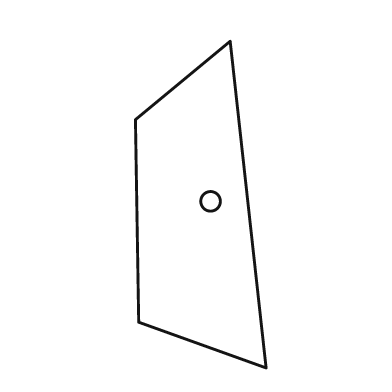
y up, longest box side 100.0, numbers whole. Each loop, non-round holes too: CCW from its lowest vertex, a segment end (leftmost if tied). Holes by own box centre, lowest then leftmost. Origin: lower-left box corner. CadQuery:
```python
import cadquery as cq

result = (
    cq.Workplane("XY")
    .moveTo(40.0, 0.0)
    .lineTo(29.0, 100.0)
    .lineTo(0.0, 76.0)
    .lineTo(1.0, 14.0)
    .close()
    .moveTo(23.0, 51.0)
    .circle(3.0)
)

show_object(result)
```